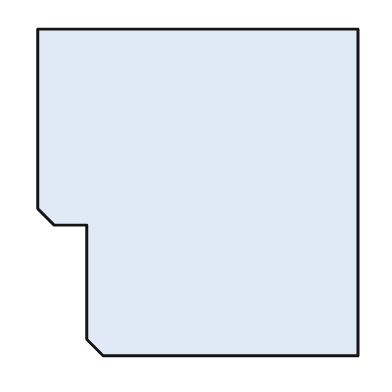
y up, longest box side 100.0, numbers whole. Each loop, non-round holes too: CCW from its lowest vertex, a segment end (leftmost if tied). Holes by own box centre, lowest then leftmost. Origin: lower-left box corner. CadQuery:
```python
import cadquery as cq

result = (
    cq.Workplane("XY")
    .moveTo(20.0, 0.0)
    .lineTo(98.0, 0.0)
    .lineTo(98.0, 100.0)
    .lineTo(0.0, 100.0)
    .lineTo(0.0, 45.0)
    .lineTo(5.0, 40.0)
    .lineTo(15.0, 40.0)
    .lineTo(15.0, 5.0)
    .close()
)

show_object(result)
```